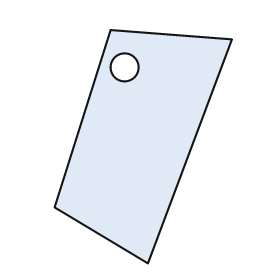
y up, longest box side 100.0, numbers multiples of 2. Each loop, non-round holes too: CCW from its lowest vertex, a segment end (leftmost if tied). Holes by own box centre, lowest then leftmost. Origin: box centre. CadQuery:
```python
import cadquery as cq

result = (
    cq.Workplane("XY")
    .moveTo(2.0, -50.0)
    .lineTo(38.0, 46.0)
    .lineTo(-14.0, 50.0)
    .lineTo(-38.0, -26.0)
    .close()
    .moveTo(-8.0, 34.0)
    .circle(6.0)
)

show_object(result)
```